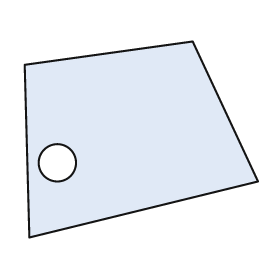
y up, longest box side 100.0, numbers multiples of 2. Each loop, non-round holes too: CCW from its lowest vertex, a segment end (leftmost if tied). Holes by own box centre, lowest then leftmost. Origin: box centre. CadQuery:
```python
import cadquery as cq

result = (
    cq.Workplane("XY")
    .moveTo(-48.0, -42.0)
    .lineTo(50.0, -18.0)
    .lineTo(22.0, 42.0)
    .lineTo(-50.0, 32.0)
    .close()
    .moveTo(-36.0, -10.0)
    .circle(8.0)
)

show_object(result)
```